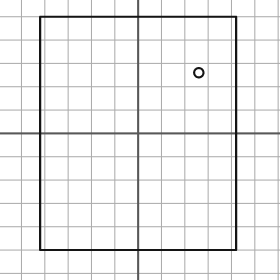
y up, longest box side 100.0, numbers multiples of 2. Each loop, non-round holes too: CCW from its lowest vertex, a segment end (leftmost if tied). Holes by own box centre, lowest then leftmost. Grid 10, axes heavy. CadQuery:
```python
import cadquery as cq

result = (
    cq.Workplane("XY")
    .moveTo(-42.0, -50.0)
    .lineTo(42.0, -50.0)
    .lineTo(42.0, 50.0)
    .lineTo(-42.0, 50.0)
    .close()
    .moveTo(26.0, 26.0)
    .circle(2.0)
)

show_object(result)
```